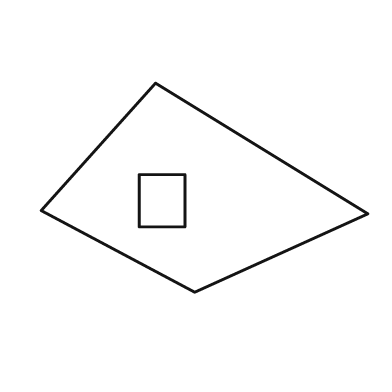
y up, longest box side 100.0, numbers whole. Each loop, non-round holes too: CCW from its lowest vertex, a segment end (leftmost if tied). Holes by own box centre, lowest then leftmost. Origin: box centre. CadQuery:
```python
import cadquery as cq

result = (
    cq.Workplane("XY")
    .moveTo(-3.0, -32.0)
    .lineTo(50.0, -8.0)
    .lineTo(-15.0, 32.0)
    .lineTo(-50.0, -7.0)
    .close()
    .moveTo(-20.0, -12.0)
    .lineTo(-6.0, -12.0)
    .lineTo(-6.0, 4.0)
    .lineTo(-20.0, 4.0)
    .close()
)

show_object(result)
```